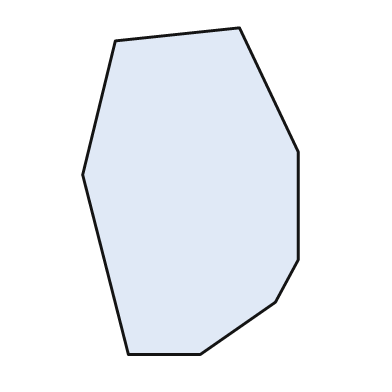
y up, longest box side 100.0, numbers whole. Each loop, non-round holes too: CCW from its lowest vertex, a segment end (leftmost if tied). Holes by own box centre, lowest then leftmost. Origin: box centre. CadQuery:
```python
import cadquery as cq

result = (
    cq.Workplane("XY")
    .moveTo(-19.0, -50.0)
    .lineTo(3.0, -50.0)
    .lineTo(26.0, -34.0)
    .lineTo(33.0, -21.0)
    .lineTo(33.0, 12.0)
    .lineTo(15.0, 50.0)
    .lineTo(-23.0, 46.0)
    .lineTo(-33.0, 5.0)
    .close()
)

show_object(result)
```